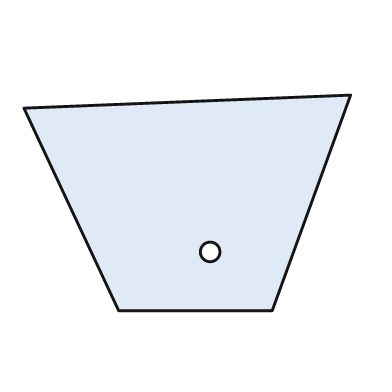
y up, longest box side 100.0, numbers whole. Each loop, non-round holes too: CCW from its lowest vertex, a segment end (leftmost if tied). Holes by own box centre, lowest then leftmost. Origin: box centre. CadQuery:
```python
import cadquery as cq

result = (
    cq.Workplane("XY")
    .moveTo(-21.0, -33.0)
    .lineTo(26.0, -33.0)
    .lineTo(50.0, 33.0)
    .lineTo(-50.0, 29.0)
    .close()
    .moveTo(7.0, -15.0)
    .circle(3.0)
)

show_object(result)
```